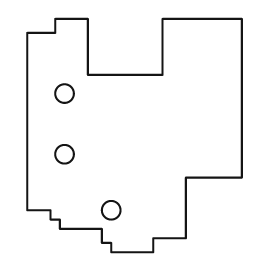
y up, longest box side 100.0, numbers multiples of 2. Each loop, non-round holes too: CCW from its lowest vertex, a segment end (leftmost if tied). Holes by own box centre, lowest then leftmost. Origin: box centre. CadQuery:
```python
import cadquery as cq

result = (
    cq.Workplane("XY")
    .moveTo(-10.0, -50.0)
    .lineTo(8.0, -50.0)
    .lineTo(8.0, -44.0)
    .lineTo(22.0, -44.0)
    .lineTo(22.0, -18.0)
    .lineTo(46.0, -18.0)
    .lineTo(46.0, 50.0)
    .lineTo(12.0, 50.0)
    .lineTo(12.0, 26.0)
    .lineTo(-20.0, 26.0)
    .lineTo(-20.0, 50.0)
    .lineTo(-34.0, 50.0)
    .lineTo(-34.0, 44.0)
    .lineTo(-46.0, 44.0)
    .lineTo(-46.0, -32.0)
    .lineTo(-36.0, -32.0)
    .lineTo(-36.0, -36.0)
    .lineTo(-32.0, -36.0)
    .lineTo(-32.0, -40.0)
    .lineTo(-14.0, -40.0)
    .lineTo(-14.0, -46.0)
    .lineTo(-10.0, -46.0)
    .close()
    .moveTo(-10.0, -32.0)
    .circle(4.0)
    .moveTo(-30.0, -8.0)
    .circle(4.0)
    .moveTo(-30.0, 18.0)
    .circle(4.0)
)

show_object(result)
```